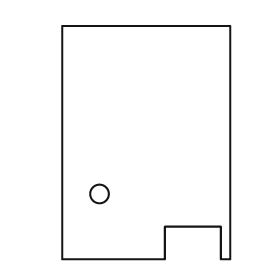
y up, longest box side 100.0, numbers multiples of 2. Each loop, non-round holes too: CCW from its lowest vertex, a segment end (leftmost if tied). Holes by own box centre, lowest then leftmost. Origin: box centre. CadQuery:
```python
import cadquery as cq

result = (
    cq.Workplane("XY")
    .moveTo(-36.0, -50.0)
    .lineTo(8.0, -50.0)
    .lineTo(8.0, -36.0)
    .lineTo(32.0, -36.0)
    .lineTo(32.0, -50.0)
    .lineTo(36.0, -50.0)
    .lineTo(36.0, 50.0)
    .lineTo(-36.0, 50.0)
    .close()
    .moveTo(-20.0, -22.0)
    .circle(4.0)
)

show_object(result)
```